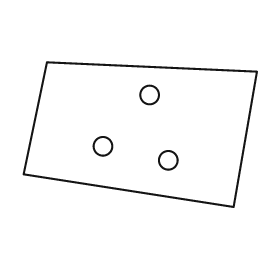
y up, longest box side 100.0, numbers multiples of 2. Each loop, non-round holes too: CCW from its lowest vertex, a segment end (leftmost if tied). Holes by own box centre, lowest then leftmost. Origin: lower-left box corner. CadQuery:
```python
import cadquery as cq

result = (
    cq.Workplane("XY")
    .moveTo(90.0, 0.0)
    .lineTo(100.0, 58.0)
    .lineTo(10.0, 62.0)
    .lineTo(0.0, 14.0)
    .close()
    .moveTo(62.0, 20.0)
    .circle(4.0)
    .moveTo(34.0, 26.0)
    .circle(4.0)
    .moveTo(54.0, 48.0)
    .circle(4.0)
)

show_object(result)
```